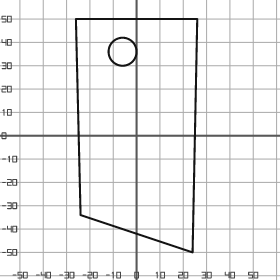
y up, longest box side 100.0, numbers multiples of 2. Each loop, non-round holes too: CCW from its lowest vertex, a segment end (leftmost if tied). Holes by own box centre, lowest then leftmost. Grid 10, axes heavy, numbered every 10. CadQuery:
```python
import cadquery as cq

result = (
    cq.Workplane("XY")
    .moveTo(24.0, -50.0)
    .lineTo(26.0, 50.0)
    .lineTo(-26.0, 50.0)
    .lineTo(-24.0, -34.0)
    .close()
    .moveTo(-6.0, 36.0)
    .circle(6.0)
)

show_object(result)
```